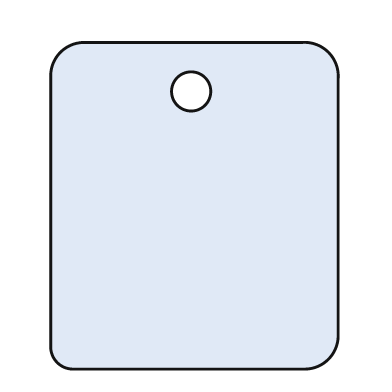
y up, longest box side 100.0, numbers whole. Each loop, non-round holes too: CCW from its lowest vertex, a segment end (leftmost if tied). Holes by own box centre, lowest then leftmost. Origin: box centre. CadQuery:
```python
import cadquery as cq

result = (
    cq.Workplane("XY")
    .moveTo(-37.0, -50.0)
    .lineTo(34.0, -50.0)
    .threePointArc((41.0, -47.0), (44.0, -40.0))
    .lineTo(44.0, 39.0)
    .threePointArc((41.0, 47.0), (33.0, 50.0))
    .lineTo(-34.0, 50.0)
    .threePointArc((-41.0, 47.0), (-44.0, 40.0))
    .lineTo(-44.0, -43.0)
    .threePointArc((-42.0, -48.0), (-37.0, -50.0))
    .close()
    .moveTo(-1.0, 35.0)
    .circle(6.0)
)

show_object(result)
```